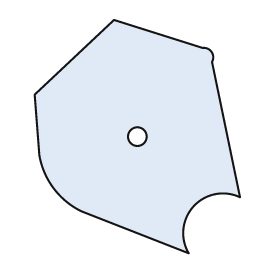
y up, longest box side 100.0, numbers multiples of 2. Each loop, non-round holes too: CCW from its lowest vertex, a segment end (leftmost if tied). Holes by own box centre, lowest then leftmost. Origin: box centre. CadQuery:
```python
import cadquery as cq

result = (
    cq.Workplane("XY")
    .moveTo(22.0, -50.0)
    .threePointArc((24.0, -30.0), (44.0, -26.0))
    .lineTo(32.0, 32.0)
    .threePointArc((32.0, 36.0), (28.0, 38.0))
    .lineTo(-10.0, 50.0)
    .lineTo(-44.0, 18.0)
    .lineTo(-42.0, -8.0)
    .threePointArc((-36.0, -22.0), (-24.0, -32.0))
    .close()
    .moveTo(0.0, 0.0)
    .circle(4.0)
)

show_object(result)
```